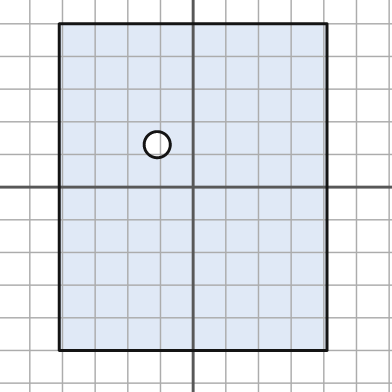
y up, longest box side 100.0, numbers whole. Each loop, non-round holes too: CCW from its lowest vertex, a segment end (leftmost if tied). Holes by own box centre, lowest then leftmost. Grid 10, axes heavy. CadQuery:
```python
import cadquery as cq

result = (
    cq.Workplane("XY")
    .moveTo(-41.0, -50.0)
    .lineTo(41.0, -50.0)
    .lineTo(41.0, 50.0)
    .lineTo(-41.0, 50.0)
    .close()
    .moveTo(-11.0, 13.0)
    .circle(4.0)
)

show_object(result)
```